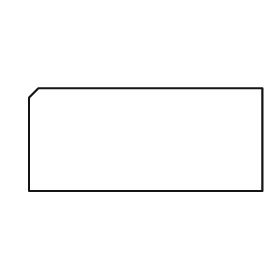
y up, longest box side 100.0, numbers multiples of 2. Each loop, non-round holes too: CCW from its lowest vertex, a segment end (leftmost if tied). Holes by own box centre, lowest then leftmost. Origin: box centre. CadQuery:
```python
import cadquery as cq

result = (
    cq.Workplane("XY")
    .moveTo(-50.0, -22.0)
    .lineTo(50.0, -22.0)
    .lineTo(50.0, 22.0)
    .lineTo(-46.0, 22.0)
    .lineTo(-50.0, 18.0)
    .close()
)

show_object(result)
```